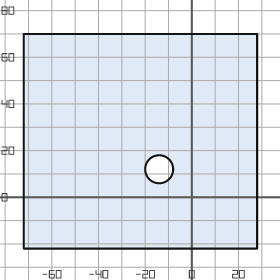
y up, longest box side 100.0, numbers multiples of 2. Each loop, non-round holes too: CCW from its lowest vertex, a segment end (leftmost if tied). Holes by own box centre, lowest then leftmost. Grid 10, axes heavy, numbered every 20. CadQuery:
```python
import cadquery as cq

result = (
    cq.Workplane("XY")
    .moveTo(-72.0, -22.0)
    .lineTo(28.0, -22.0)
    .lineTo(28.0, 70.0)
    .lineTo(-72.0, 70.0)
    .close()
    .moveTo(-14.0, 12.0)
    .circle(6.0)
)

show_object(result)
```